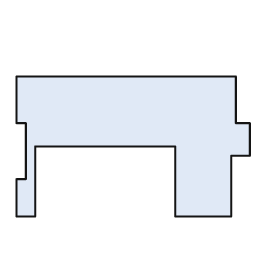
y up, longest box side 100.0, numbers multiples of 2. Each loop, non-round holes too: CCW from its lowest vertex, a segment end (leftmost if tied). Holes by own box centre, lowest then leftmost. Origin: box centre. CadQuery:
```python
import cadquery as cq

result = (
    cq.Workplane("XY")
    .moveTo(-50.0, -30.0)
    .lineTo(-42.0, -30.0)
    .lineTo(-42.0, 0.0)
    .lineTo(18.0, 0.0)
    .lineTo(18.0, -30.0)
    .lineTo(42.0, -30.0)
    .lineTo(42.0, -4.0)
    .lineTo(50.0, -4.0)
    .lineTo(50.0, 10.0)
    .lineTo(44.0, 10.0)
    .lineTo(44.0, 30.0)
    .lineTo(-50.0, 30.0)
    .lineTo(-50.0, 10.0)
    .lineTo(-46.0, 10.0)
    .lineTo(-46.0, -14.0)
    .lineTo(-50.0, -14.0)
    .close()
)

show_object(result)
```